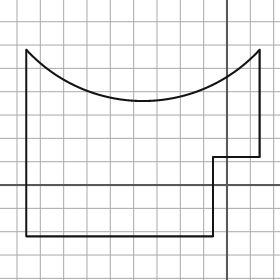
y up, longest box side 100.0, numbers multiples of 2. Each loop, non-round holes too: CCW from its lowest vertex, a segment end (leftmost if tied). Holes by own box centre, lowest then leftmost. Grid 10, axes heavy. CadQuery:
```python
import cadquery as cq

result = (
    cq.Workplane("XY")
    .moveTo(-86.0, -22.0)
    .lineTo(-6.0, -22.0)
    .lineTo(-6.0, 12.0)
    .lineTo(14.0, 12.0)
    .lineTo(14.0, 58.0)
    .threePointArc((-36.0, 36.0), (-86.0, 58.0))
    .close()
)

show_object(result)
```